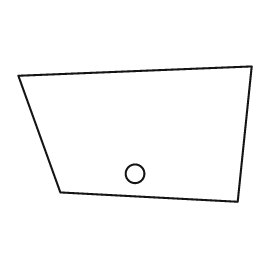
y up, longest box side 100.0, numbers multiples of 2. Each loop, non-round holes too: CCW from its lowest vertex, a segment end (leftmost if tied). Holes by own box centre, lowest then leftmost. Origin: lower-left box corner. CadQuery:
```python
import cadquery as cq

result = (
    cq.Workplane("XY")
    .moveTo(94.0, 0.0)
    .lineTo(100.0, 58.0)
    .lineTo(0.0, 54.0)
    .lineTo(18.0, 4.0)
    .close()
    .moveTo(50.0, 12.0)
    .circle(4.0)
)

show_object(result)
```